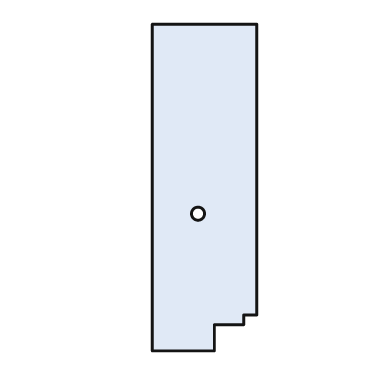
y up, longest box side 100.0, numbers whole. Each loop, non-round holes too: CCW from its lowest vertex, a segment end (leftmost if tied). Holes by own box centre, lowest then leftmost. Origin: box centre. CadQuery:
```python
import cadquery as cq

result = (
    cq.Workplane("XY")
    .moveTo(-16.0, -50.0)
    .lineTo(3.0, -50.0)
    .lineTo(3.0, -42.0)
    .lineTo(12.0, -42.0)
    .lineTo(12.0, -39.0)
    .lineTo(16.0, -39.0)
    .lineTo(16.0, 50.0)
    .lineTo(-16.0, 50.0)
    .close()
    .moveTo(-2.0, -8.0)
    .circle(2.0)
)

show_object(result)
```